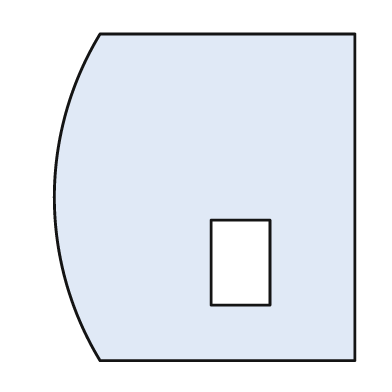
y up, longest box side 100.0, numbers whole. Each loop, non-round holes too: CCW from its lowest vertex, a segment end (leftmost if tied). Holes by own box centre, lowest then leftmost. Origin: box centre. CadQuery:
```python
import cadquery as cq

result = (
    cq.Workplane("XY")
    .moveTo(-32.0, -50.0)
    .lineTo(46.0, -50.0)
    .lineTo(46.0, 50.0)
    .lineTo(-32.0, 50.0)
    .threePointArc((-46.0, 0.0), (-32.0, -50.0))
    .close()
    .moveTo(2.0, -33.0)
    .lineTo(20.0, -33.0)
    .lineTo(20.0, -7.0)
    .lineTo(2.0, -7.0)
    .close()
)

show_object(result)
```